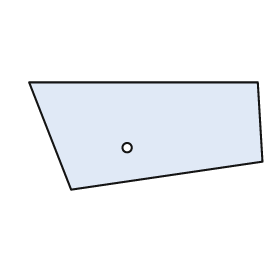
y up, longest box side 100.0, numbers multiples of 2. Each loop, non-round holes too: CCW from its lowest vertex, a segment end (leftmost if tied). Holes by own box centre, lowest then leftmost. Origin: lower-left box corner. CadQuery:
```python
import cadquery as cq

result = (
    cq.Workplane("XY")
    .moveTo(18.0, 0.0)
    .lineTo(100.0, 12.0)
    .lineTo(98.0, 46.0)
    .lineTo(0.0, 46.0)
    .close()
    .moveTo(42.0, 18.0)
    .circle(2.0)
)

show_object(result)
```